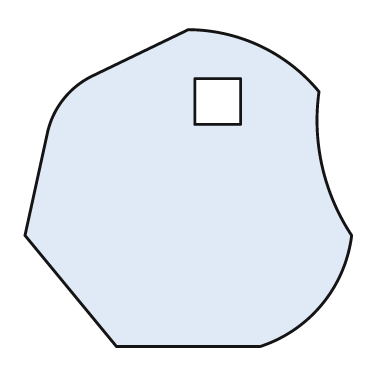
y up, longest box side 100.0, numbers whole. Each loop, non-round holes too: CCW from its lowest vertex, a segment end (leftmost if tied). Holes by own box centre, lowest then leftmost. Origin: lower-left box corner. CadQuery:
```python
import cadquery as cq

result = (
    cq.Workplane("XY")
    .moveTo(28.0, 0.0)
    .lineTo(72.0, 0.0)
    .threePointArc((91.0, 13.0), (100.0, 34.0))
    .threePointArc((91.0, 55.0), (90.0, 78.0))
    .threePointArc((72.0, 92.0), (50.0, 97.0))
    .lineTo(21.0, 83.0)
    .threePointArc((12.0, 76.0), (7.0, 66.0))
    .lineTo(0.0, 34.0)
    .close()
    .moveTo(52.0, 68.0)
    .lineTo(66.0, 68.0)
    .lineTo(66.0, 82.0)
    .lineTo(52.0, 82.0)
    .close()
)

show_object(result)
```